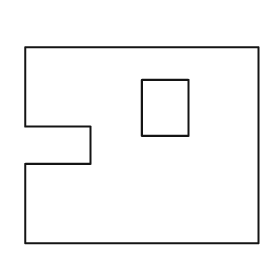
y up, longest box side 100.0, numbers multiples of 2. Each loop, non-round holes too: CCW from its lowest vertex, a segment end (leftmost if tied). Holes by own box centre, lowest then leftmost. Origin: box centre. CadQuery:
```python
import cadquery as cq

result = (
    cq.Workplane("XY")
    .moveTo(-50.0, -42.0)
    .lineTo(50.0, -42.0)
    .lineTo(50.0, 42.0)
    .lineTo(-50.0, 42.0)
    .lineTo(-50.0, 8.0)
    .lineTo(-22.0, 8.0)
    .lineTo(-22.0, -8.0)
    .lineTo(-50.0, -8.0)
    .close()
    .moveTo(0.0, 4.0)
    .lineTo(20.0, 4.0)
    .lineTo(20.0, 28.0)
    .lineTo(0.0, 28.0)
    .close()
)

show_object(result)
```